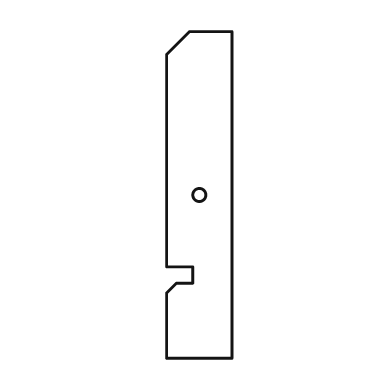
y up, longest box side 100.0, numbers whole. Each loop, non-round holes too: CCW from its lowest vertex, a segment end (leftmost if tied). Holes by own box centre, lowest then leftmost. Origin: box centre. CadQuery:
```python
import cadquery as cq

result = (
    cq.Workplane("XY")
    .moveTo(-10.0, -50.0)
    .lineTo(10.0, -50.0)
    .lineTo(10.0, 50.0)
    .lineTo(-3.0, 50.0)
    .lineTo(-10.0, 43.0)
    .lineTo(-10.0, -22.0)
    .lineTo(-2.0, -22.0)
    .lineTo(-2.0, -27.0)
    .lineTo(-7.0, -27.0)
    .lineTo(-10.0, -30.0)
    .close()
    .moveTo(0.0, 0.0)
    .circle(2.0)
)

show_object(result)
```